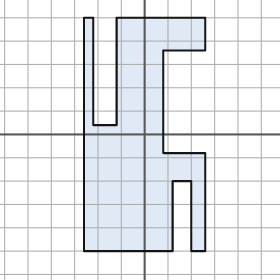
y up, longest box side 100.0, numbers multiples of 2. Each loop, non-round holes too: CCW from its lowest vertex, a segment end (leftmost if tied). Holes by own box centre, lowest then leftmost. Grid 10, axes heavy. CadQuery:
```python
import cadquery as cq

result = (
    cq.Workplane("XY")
    .moveTo(-26.0, -50.0)
    .lineTo(12.0, -50.0)
    .lineTo(12.0, -20.0)
    .lineTo(20.0, -20.0)
    .lineTo(20.0, -50.0)
    .lineTo(26.0, -50.0)
    .lineTo(26.0, -8.0)
    .lineTo(8.0, -8.0)
    .lineTo(8.0, 36.0)
    .lineTo(26.0, 36.0)
    .lineTo(26.0, 50.0)
    .lineTo(-12.0, 50.0)
    .lineTo(-12.0, 4.0)
    .lineTo(-22.0, 4.0)
    .lineTo(-22.0, 50.0)
    .lineTo(-26.0, 50.0)
    .close()
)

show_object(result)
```